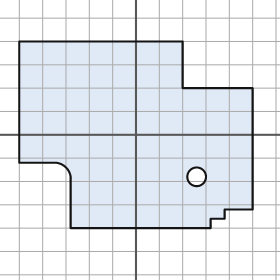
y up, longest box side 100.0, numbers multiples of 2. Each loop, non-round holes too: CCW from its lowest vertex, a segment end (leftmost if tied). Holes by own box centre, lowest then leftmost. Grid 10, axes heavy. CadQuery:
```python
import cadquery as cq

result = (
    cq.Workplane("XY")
    .moveTo(-28.0, -40.0)
    .lineTo(32.0, -40.0)
    .lineTo(32.0, -36.0)
    .lineTo(38.0, -36.0)
    .lineTo(38.0, -32.0)
    .lineTo(50.0, -32.0)
    .lineTo(50.0, 20.0)
    .lineTo(20.0, 20.0)
    .lineTo(20.0, 40.0)
    .lineTo(-50.0, 40.0)
    .lineTo(-50.0, -12.0)
    .lineTo(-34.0, -12.0)
    .threePointArc((-30.0, -14.0), (-28.0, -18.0))
    .close()
    .moveTo(26.0, -18.0)
    .circle(4.0)
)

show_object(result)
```